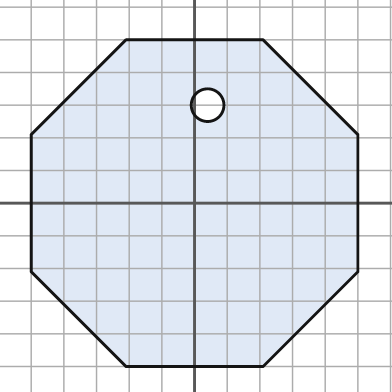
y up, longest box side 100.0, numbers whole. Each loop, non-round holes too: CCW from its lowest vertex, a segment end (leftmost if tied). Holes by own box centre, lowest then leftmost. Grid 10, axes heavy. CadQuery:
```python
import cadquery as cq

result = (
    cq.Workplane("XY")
    .moveTo(-21.0, -50.0)
    .lineTo(21.0, -50.0)
    .lineTo(50.0, -21.0)
    .lineTo(50.0, 21.0)
    .lineTo(21.0, 50.0)
    .lineTo(-21.0, 50.0)
    .lineTo(-50.0, 21.0)
    .lineTo(-50.0, -21.0)
    .close()
    .moveTo(4.0, 30.0)
    .circle(5.0)
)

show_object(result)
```